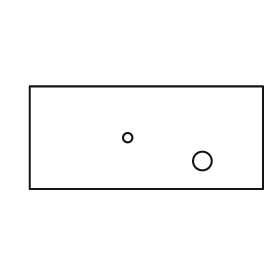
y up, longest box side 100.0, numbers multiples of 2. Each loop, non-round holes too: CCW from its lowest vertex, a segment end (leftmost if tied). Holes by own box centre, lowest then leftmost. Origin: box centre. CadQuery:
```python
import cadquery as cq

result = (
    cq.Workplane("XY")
    .moveTo(-50.0, -22.0)
    .lineTo(50.0, -22.0)
    .lineTo(50.0, 22.0)
    .lineTo(-50.0, 22.0)
    .close()
    .moveTo(24.0, -10.0)
    .circle(4.0)
    .moveTo(-8.0, 0.0)
    .circle(2.0)
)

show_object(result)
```